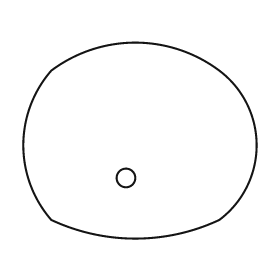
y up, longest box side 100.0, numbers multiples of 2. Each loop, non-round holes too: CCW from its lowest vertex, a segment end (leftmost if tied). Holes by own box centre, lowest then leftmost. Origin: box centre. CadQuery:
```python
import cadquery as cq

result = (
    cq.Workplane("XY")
    .moveTo(-38.0, -34.0)
    .threePointArc((-2.0, -42.0), (34.0, -34.0))
    .threePointArc((50.0, -2.0), (34.0, 30.0))
    .threePointArc((-2.0, 42.0), (-38.0, 30.0))
    .threePointArc((-50.0, -2.0), (-38.0, -34.0))
    .close()
    .moveTo(-6.0, -16.0)
    .circle(4.0)
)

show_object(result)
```